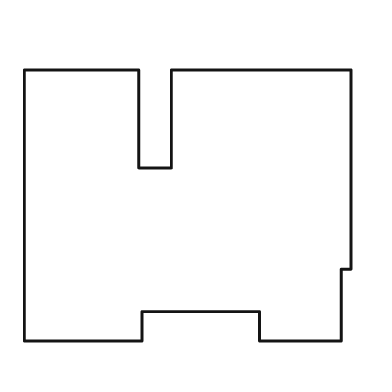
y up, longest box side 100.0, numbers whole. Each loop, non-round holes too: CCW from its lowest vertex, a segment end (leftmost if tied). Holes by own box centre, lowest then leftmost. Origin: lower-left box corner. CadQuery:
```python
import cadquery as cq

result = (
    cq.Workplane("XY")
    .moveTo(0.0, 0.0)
    .lineTo(36.0, 0.0)
    .lineTo(36.0, 9.0)
    .lineTo(72.0, 9.0)
    .lineTo(72.0, 0.0)
    .lineTo(97.0, 0.0)
    .lineTo(97.0, 22.0)
    .lineTo(100.0, 22.0)
    .lineTo(100.0, 83.0)
    .lineTo(45.0, 83.0)
    .lineTo(45.0, 53.0)
    .lineTo(35.0, 53.0)
    .lineTo(35.0, 83.0)
    .lineTo(0.0, 83.0)
    .close()
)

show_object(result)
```